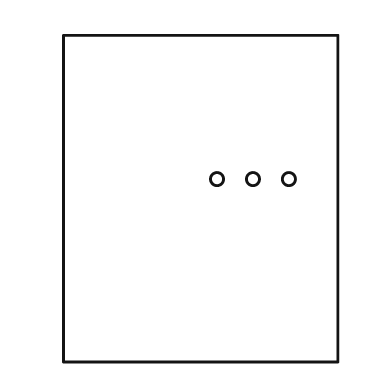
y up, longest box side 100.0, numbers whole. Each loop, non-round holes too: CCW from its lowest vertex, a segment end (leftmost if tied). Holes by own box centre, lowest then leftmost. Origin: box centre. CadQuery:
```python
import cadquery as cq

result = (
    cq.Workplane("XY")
    .moveTo(-42.0, -50.0)
    .lineTo(42.0, -50.0)
    .lineTo(42.0, 50.0)
    .lineTo(-42.0, 50.0)
    .close()
    .moveTo(5.0, 6.0)
    .circle(2.0)
    .moveTo(16.0, 6.0)
    .circle(2.0)
    .moveTo(27.0, 6.0)
    .circle(2.0)
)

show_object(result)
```